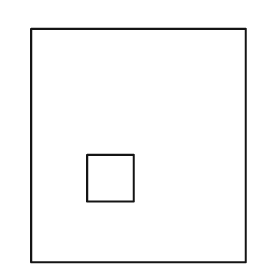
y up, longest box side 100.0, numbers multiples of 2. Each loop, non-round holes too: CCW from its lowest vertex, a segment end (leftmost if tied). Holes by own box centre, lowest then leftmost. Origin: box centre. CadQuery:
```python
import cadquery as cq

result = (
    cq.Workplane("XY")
    .moveTo(-46.0, -50.0)
    .lineTo(46.0, -50.0)
    .lineTo(46.0, 50.0)
    .lineTo(-46.0, 50.0)
    .close()
    .moveTo(-22.0, -24.0)
    .lineTo(-2.0, -24.0)
    .lineTo(-2.0, -4.0)
    .lineTo(-22.0, -4.0)
    .close()
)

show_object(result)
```